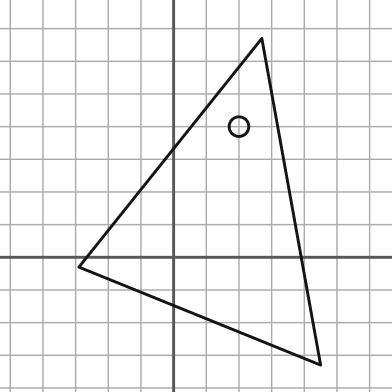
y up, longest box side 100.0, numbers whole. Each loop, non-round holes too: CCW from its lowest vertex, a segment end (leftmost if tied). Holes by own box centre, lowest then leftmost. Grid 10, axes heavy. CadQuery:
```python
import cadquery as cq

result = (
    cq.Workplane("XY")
    .moveTo(45.0, -33.0)
    .lineTo(27.0, 67.0)
    .lineTo(-29.0, -3.0)
    .close()
    .moveTo(20.0, 40.0)
    .circle(3.0)
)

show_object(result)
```